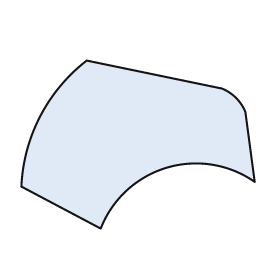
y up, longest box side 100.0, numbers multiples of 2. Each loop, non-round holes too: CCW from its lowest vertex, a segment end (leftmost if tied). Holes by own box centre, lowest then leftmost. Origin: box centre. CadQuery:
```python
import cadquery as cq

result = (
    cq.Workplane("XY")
    .moveTo(-16.0, -36.0)
    .threePointArc((12.0, -10.0), (50.0, -16.0))
    .lineTo(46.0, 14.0)
    .threePointArc((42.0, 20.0), (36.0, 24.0))
    .lineTo(-22.0, 36.0)
    .threePointArc((-42.0, 12.0), (-50.0, -18.0))
    .close()
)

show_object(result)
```